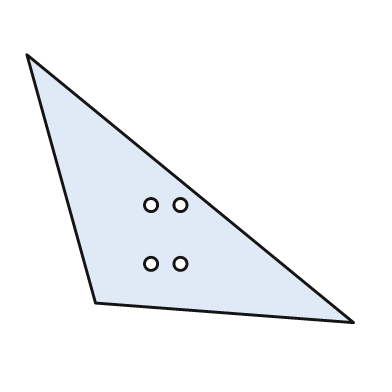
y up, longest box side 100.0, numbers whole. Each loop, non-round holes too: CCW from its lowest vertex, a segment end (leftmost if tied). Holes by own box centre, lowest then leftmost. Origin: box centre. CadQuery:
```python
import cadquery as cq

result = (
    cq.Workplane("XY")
    .moveTo(50.0, -41.0)
    .lineTo(-50.0, 41.0)
    .lineTo(-29.0, -35.0)
    .close()
    .moveTo(-12.0, -23.0)
    .circle(2.0)
    .moveTo(-3.0, -23.0)
    .circle(2.0)
    .moveTo(-12.0, -5.0)
    .circle(2.0)
    .moveTo(-3.0, -5.0)
    .circle(2.0)
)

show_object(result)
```